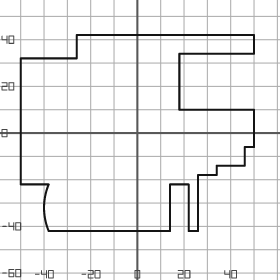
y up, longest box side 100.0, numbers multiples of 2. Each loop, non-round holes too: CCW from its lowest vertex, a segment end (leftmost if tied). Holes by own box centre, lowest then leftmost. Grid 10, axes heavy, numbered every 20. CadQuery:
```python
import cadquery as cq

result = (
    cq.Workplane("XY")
    .moveTo(-38.0, -42.0)
    .lineTo(14.0, -42.0)
    .lineTo(14.0, -22.0)
    .lineTo(22.0, -22.0)
    .lineTo(22.0, -42.0)
    .lineTo(26.0, -42.0)
    .lineTo(26.0, -18.0)
    .lineTo(34.0, -18.0)
    .lineTo(34.0, -14.0)
    .lineTo(46.0, -14.0)
    .lineTo(46.0, -6.0)
    .lineTo(50.0, -6.0)
    .lineTo(50.0, 10.0)
    .lineTo(18.0, 10.0)
    .lineTo(18.0, 34.0)
    .lineTo(50.0, 34.0)
    .lineTo(50.0, 42.0)
    .lineTo(-26.0, 42.0)
    .lineTo(-26.0, 32.0)
    .lineTo(-50.0, 32.0)
    .lineTo(-50.0, -22.0)
    .lineTo(-38.0, -22.0)
    .threePointArc((-40.0, -32.0), (-38.0, -42.0))
    .close()
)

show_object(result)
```